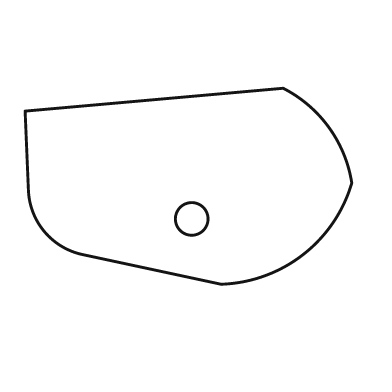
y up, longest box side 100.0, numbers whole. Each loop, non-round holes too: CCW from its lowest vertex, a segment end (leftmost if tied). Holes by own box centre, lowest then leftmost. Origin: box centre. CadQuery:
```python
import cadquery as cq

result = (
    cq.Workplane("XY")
    .moveTo(10.0, -30.0)
    .threePointArc((35.0, -21.0), (50.0, 1.0))
    .threePointArc((43.0, 18.0), (29.0, 30.0))
    .lineTo(-50.0, 23.0)
    .lineTo(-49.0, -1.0)
    .threePointArc((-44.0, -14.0), (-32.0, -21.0))
    .close()
    .moveTo(1.0, -10.0)
    .circle(5.0)
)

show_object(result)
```